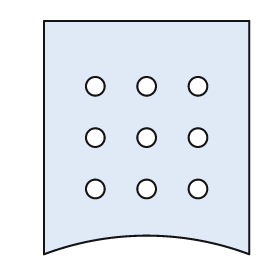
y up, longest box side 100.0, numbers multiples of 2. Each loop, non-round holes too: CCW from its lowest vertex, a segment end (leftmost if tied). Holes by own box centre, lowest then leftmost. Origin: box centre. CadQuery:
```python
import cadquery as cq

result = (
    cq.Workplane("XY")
    .moveTo(-44.0, -50.0)
    .threePointArc((0.0, -42.0), (44.0, -50.0))
    .lineTo(44.0, 50.0)
    .lineTo(-44.0, 50.0)
    .close()
    .moveTo(-22.0, -22.0)
    .circle(4.0)
    .moveTo(0.0, -22.0)
    .circle(4.0)
    .moveTo(22.0, -22.0)
    .circle(4.0)
    .moveTo(-22.0, 0.0)
    .circle(4.0)
    .moveTo(0.0, 0.0)
    .circle(4.0)
    .moveTo(22.0, 0.0)
    .circle(4.0)
    .moveTo(-22.0, 22.0)
    .circle(4.0)
    .moveTo(0.0, 22.0)
    .circle(4.0)
    .moveTo(22.0, 22.0)
    .circle(4.0)
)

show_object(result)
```